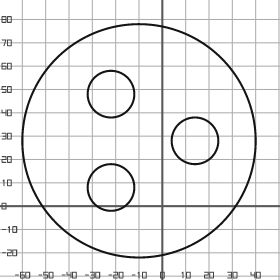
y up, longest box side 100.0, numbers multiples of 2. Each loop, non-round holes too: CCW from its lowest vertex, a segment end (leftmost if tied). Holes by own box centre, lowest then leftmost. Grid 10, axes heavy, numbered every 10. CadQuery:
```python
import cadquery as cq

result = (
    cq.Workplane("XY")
    .moveTo(-10.0, 28.0)
    .circle(50.0)
    .moveTo(-22.0, 8.0)
    .circle(10.0)
    .moveTo(14.0, 28.0)
    .circle(10.0)
    .moveTo(-22.0, 48.0)
    .circle(10.0)
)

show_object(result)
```